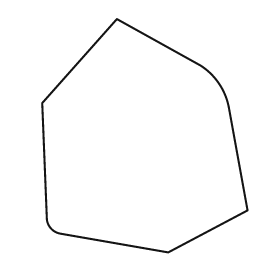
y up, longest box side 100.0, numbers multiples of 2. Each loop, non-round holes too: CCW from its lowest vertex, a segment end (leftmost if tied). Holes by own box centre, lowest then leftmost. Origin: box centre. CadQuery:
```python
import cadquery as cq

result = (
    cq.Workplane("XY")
    .moveTo(10.0, -50.0)
    .lineTo(44.0, -32.0)
    .lineTo(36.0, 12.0)
    .threePointArc((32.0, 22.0), (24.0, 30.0))
    .lineTo(-12.0, 50.0)
    .lineTo(-44.0, 14.0)
    .lineTo(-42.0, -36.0)
    .threePointArc((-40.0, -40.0), (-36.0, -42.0))
    .close()
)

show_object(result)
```